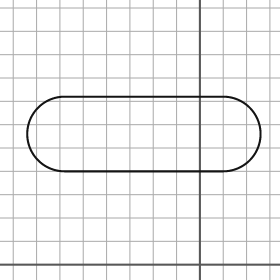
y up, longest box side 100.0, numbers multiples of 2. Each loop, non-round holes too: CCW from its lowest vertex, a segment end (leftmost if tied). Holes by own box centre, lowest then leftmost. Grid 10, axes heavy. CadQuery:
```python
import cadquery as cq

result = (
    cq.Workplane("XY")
    .moveTo(-58.0, 40.0)
    .lineTo(10.0, 40.0)
    .threePointArc((26.0, 56.0), (10.0, 72.0))
    .lineTo(-58.0, 72.0)
    .threePointArc((-74.0, 56.0), (-58.0, 40.0))
    .close()
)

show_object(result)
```